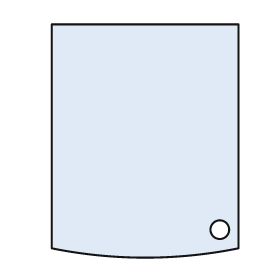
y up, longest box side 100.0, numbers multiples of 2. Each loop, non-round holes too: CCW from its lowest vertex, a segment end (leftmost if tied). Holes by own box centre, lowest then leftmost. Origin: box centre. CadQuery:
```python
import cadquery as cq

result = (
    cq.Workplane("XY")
    .moveTo(-40.0, -46.0)
    .threePointArc((0.0, -50.0), (40.0, -46.0))
    .lineTo(40.0, 50.0)
    .lineTo(-40.0, 50.0)
    .close()
    .moveTo(32.0, -38.0)
    .circle(4.0)
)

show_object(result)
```